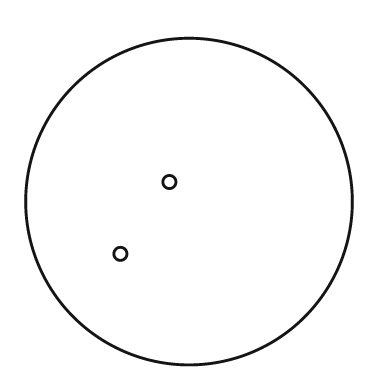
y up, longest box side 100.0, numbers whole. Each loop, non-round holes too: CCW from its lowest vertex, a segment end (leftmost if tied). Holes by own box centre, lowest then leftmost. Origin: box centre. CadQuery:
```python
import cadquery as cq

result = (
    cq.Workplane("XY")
    .moveTo(0.0, 0.0)
    .circle(50.0)
    .moveTo(-21.0, -16.0)
    .circle(2.0)
    .moveTo(-6.0, 6.0)
    .circle(2.0)
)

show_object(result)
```